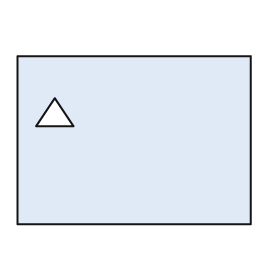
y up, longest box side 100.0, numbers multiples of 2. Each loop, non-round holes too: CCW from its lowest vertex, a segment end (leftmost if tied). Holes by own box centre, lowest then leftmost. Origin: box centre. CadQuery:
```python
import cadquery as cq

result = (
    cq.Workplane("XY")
    .moveTo(-50.0, -36.0)
    .lineTo(50.0, -36.0)
    .lineTo(50.0, 36.0)
    .lineTo(-50.0, 36.0)
    .close()
    .moveTo(-42.0, 6.0)
    .lineTo(-26.0, 6.0)
    .lineTo(-34.0, 18.0)
    .close()
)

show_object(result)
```